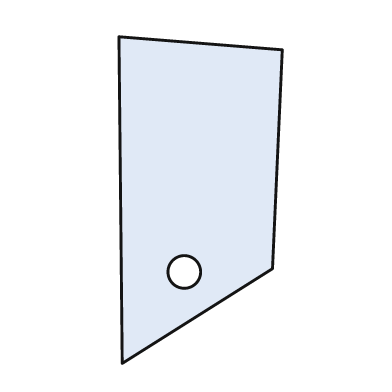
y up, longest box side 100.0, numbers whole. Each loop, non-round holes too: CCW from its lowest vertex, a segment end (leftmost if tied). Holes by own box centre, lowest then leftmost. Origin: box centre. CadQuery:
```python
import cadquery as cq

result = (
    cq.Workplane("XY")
    .moveTo(-24.0, -50.0)
    .lineTo(22.0, -21.0)
    .lineTo(25.0, 46.0)
    .lineTo(-25.0, 50.0)
    .close()
    .moveTo(-5.0, -22.0)
    .circle(5.0)
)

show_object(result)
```